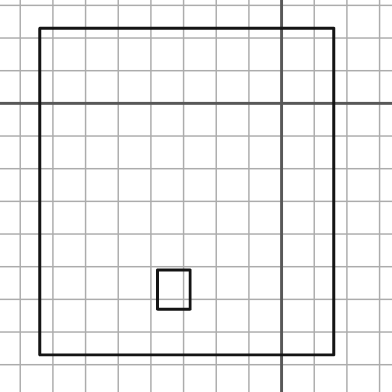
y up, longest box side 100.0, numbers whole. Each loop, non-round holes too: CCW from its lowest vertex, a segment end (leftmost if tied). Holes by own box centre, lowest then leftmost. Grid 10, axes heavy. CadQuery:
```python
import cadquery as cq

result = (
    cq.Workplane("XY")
    .moveTo(-74.0, -77.0)
    .lineTo(16.0, -77.0)
    .lineTo(16.0, 23.0)
    .lineTo(-74.0, 23.0)
    .close()
    .moveTo(-38.0, -63.0)
    .lineTo(-28.0, -63.0)
    .lineTo(-28.0, -51.0)
    .lineTo(-38.0, -51.0)
    .close()
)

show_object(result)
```